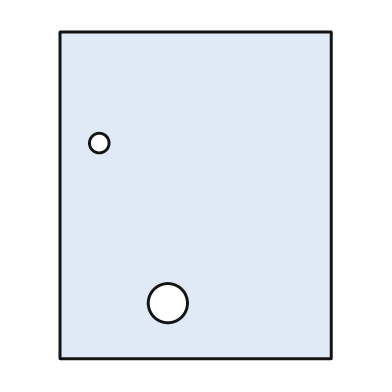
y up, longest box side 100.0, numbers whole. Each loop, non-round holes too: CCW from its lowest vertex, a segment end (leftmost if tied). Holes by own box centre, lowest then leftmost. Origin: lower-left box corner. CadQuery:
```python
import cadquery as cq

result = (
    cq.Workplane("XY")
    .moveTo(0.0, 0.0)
    .lineTo(83.0, 0.0)
    .lineTo(83.0, 100.0)
    .lineTo(0.0, 100.0)
    .close()
    .moveTo(33.0, 17.0)
    .circle(6.0)
    .moveTo(12.0, 66.0)
    .circle(3.0)
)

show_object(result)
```